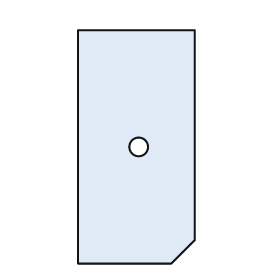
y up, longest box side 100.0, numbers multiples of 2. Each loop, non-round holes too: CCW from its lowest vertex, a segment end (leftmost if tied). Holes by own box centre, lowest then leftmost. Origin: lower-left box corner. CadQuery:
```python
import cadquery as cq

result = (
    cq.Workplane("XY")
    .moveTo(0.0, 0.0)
    .lineTo(40.0, 0.0)
    .lineTo(50.0, 10.0)
    .lineTo(50.0, 100.0)
    .lineTo(0.0, 100.0)
    .close()
    .moveTo(26.0, 50.0)
    .circle(4.0)
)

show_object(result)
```